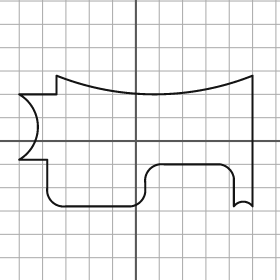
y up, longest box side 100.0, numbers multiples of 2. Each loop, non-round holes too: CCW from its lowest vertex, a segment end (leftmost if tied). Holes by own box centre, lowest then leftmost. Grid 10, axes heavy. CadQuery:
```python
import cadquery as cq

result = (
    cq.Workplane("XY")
    .moveTo(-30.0, -28.0)
    .lineTo(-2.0, -28.0)
    .threePointArc((2.0, -26.0), (4.0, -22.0))
    .lineTo(4.0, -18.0)
    .threePointArc((6.0, -12.0), (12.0, -10.0))
    .lineTo(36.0, -10.0)
    .threePointArc((40.0, -12.0), (42.0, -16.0))
    .lineTo(42.0, -28.0)
    .threePointArc((46.0, -26.0), (50.0, -28.0))
    .lineTo(50.0, 28.0)
    .threePointArc((8.0, 20.0), (-34.0, 28.0))
    .lineTo(-34.0, 20.0)
    .lineTo(-50.0, 20.0)
    .threePointArc((-42.0, 6.0), (-50.0, -8.0))
    .lineTo(-38.0, -8.0)
    .lineTo(-38.0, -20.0)
    .threePointArc((-36.0, -26.0), (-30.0, -28.0))
    .close()
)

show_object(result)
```